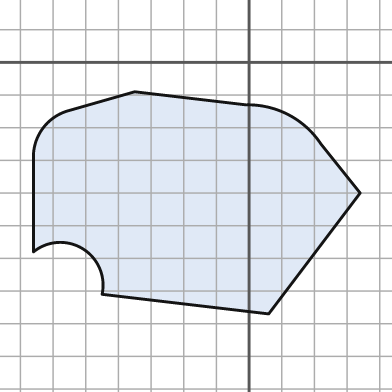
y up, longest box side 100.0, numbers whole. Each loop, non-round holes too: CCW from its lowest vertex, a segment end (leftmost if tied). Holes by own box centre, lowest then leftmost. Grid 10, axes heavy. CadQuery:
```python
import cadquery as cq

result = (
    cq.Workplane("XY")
    .moveTo(6.0, -77.0)
    .lineTo(34.0, -40.0)
    .lineTo(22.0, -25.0)
    .threePointArc((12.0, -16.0), (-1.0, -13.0))
    .lineTo(-35.0, -9.0)
    .lineTo(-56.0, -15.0)
    .threePointArc((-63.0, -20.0), (-66.0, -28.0))
    .lineTo(-66.0, -58.0)
    .threePointArc((-51.0, -57.0), (-45.0, -71.0))
    .close()
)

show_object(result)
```